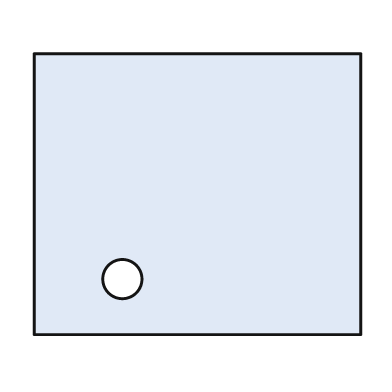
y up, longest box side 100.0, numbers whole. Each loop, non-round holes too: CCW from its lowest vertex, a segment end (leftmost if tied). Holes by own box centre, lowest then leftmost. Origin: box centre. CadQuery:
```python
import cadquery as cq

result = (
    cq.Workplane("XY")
    .moveTo(-50.0, -43.0)
    .lineTo(50.0, -43.0)
    .lineTo(50.0, 43.0)
    .lineTo(-50.0, 43.0)
    .close()
    .moveTo(-23.0, -26.0)
    .circle(6.0)
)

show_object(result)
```